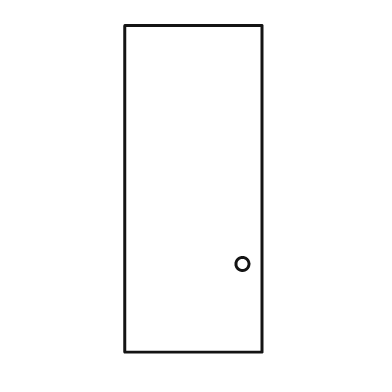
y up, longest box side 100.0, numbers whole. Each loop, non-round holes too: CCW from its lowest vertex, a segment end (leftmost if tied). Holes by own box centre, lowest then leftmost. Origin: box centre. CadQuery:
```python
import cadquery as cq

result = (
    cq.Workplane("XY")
    .moveTo(-21.0, -50.0)
    .lineTo(21.0, -50.0)
    .lineTo(21.0, 50.0)
    .lineTo(-21.0, 50.0)
    .close()
    .moveTo(15.0, -23.0)
    .circle(2.0)
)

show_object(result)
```